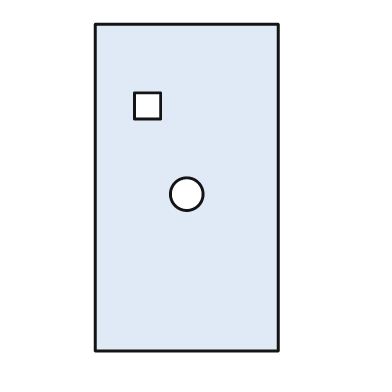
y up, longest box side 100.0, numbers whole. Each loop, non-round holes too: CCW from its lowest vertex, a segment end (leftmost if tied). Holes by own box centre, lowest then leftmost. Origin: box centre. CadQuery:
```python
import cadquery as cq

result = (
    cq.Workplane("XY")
    .moveTo(-28.0, -50.0)
    .lineTo(28.0, -50.0)
    .lineTo(28.0, 50.0)
    .lineTo(-28.0, 50.0)
    .close()
    .moveTo(0.0, -2.0)
    .circle(5.0)
    .moveTo(-16.0, 21.0)
    .lineTo(-8.0, 21.0)
    .lineTo(-8.0, 29.0)
    .lineTo(-16.0, 29.0)
    .close()
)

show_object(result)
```